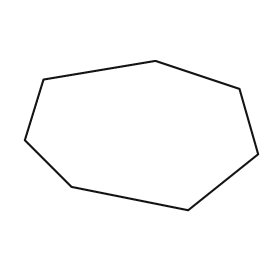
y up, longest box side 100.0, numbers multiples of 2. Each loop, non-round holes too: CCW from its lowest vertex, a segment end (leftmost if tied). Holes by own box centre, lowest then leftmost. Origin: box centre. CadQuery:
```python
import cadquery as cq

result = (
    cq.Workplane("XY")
    .moveTo(20.0, -32.0)
    .lineTo(50.0, -8.0)
    .lineTo(42.0, 20.0)
    .lineTo(6.0, 32.0)
    .lineTo(-42.0, 24.0)
    .lineTo(-50.0, -2.0)
    .lineTo(-30.0, -22.0)
    .close()
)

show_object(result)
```